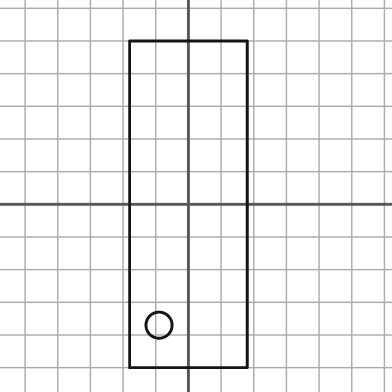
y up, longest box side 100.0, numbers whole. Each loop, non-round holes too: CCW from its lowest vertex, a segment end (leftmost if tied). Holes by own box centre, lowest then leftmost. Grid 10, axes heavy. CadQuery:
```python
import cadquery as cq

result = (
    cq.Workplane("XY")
    .moveTo(-18.0, -50.0)
    .lineTo(18.0, -50.0)
    .lineTo(18.0, 50.0)
    .lineTo(-18.0, 50.0)
    .close()
    .moveTo(-9.0, -37.0)
    .circle(4.0)
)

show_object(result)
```